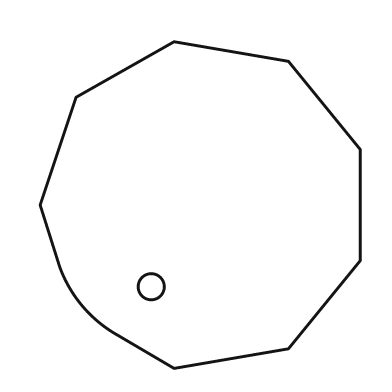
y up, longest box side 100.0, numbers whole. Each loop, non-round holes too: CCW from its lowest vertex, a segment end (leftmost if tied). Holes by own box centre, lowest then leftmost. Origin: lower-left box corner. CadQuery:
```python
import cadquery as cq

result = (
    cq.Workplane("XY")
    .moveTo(41.0, 0.0)
    .lineTo(76.0, 6.0)
    .lineTo(98.0, 33.0)
    .lineTo(98.0, 67.0)
    .lineTo(76.0, 94.0)
    .lineTo(41.0, 100.0)
    .lineTo(11.0, 83.0)
    .lineTo(0.0, 50.0)
    .lineTo(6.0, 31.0)
    .threePointArc((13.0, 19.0), (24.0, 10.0))
    .close()
    .moveTo(34.0, 25.0)
    .circle(4.0)
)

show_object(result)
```